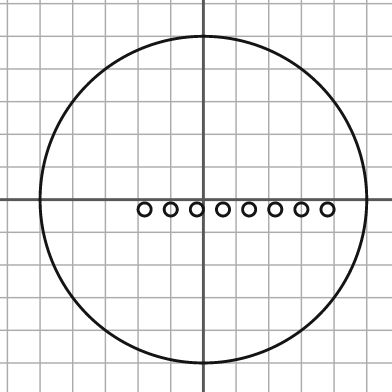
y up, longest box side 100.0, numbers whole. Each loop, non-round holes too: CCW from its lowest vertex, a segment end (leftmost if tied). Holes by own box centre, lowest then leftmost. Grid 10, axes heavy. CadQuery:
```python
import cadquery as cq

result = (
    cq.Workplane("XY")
    .moveTo(0.0, 0.0)
    .circle(50.0)
    .moveTo(-18.0, -3.0)
    .circle(2.0)
    .moveTo(-10.0, -3.0)
    .circle(2.0)
    .moveTo(-2.0, -3.0)
    .circle(2.0)
    .moveTo(6.0, -3.0)
    .circle(2.0)
    .moveTo(14.0, -3.0)
    .circle(2.0)
    .moveTo(22.0, -3.0)
    .circle(2.0)
    .moveTo(30.0, -3.0)
    .circle(2.0)
    .moveTo(38.0, -3.0)
    .circle(2.0)
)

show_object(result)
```